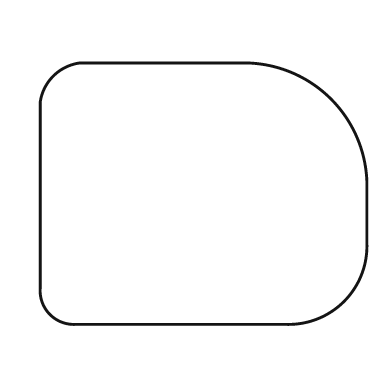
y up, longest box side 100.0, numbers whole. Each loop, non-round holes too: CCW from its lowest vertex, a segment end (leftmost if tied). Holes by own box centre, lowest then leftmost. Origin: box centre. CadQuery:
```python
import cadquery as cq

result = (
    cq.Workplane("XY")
    .moveTo(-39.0, -40.0)
    .lineTo(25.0, -40.0)
    .threePointArc((43.0, -33.0), (50.0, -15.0))
    .lineTo(50.0, 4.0)
    .threePointArc((39.0, 29.0), (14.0, 40.0))
    .lineTo(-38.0, 40.0)
    .threePointArc((-46.0, 36.0), (-50.0, 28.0))
    .lineTo(-50.0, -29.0)
    .threePointArc((-47.0, -37.0), (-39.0, -40.0))
    .close()
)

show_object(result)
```